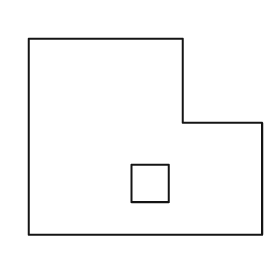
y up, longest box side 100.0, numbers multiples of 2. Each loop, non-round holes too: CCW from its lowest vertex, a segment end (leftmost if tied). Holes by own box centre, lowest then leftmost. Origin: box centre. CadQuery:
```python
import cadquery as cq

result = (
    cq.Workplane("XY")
    .moveTo(-50.0, -42.0)
    .lineTo(50.0, -42.0)
    .lineTo(50.0, 6.0)
    .lineTo(16.0, 6.0)
    .lineTo(16.0, 42.0)
    .lineTo(-50.0, 42.0)
    .close()
    .moveTo(-6.0, -28.0)
    .lineTo(10.0, -28.0)
    .lineTo(10.0, -12.0)
    .lineTo(-6.0, -12.0)
    .close()
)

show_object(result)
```